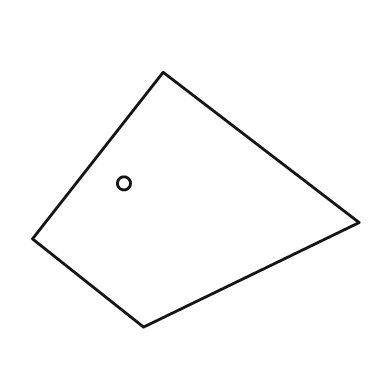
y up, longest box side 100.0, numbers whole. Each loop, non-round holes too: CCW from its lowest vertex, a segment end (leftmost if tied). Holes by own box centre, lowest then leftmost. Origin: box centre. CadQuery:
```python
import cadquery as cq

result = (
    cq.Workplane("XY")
    .moveTo(-16.0, -39.0)
    .lineTo(50.0, -7.0)
    .lineTo(-10.0, 39.0)
    .lineTo(-50.0, -12.0)
    .close()
    .moveTo(-22.0, 5.0)
    .circle(2.0)
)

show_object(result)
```